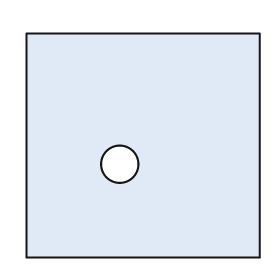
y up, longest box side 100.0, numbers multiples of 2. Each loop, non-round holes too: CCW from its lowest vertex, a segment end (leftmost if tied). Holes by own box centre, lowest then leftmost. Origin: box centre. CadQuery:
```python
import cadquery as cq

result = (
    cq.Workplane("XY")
    .moveTo(-50.0, -48.0)
    .lineTo(50.0, -48.0)
    .lineTo(50.0, 48.0)
    .lineTo(-50.0, 48.0)
    .close()
    .moveTo(-10.0, -8.0)
    .circle(8.0)
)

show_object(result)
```